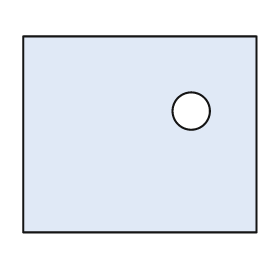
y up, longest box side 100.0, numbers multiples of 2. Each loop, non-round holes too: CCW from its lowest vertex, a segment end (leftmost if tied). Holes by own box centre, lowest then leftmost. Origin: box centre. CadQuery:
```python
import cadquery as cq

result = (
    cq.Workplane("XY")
    .moveTo(-50.0, -42.0)
    .lineTo(50.0, -42.0)
    .lineTo(50.0, 42.0)
    .lineTo(-50.0, 42.0)
    .close()
    .moveTo(22.0, 10.0)
    .circle(8.0)
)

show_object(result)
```